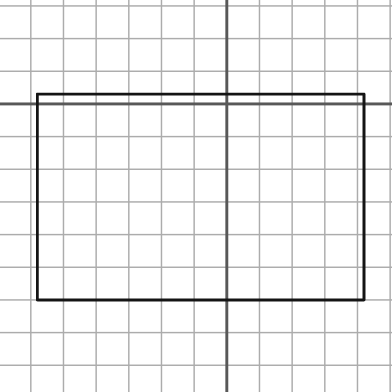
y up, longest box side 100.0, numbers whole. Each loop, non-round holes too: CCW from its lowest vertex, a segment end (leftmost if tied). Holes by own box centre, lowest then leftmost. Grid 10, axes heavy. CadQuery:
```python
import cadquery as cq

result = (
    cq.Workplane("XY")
    .moveTo(-58.0, -60.0)
    .lineTo(42.0, -60.0)
    .lineTo(42.0, 3.0)
    .lineTo(-58.0, 3.0)
    .close()
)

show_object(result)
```